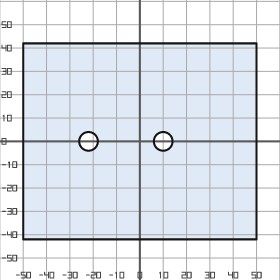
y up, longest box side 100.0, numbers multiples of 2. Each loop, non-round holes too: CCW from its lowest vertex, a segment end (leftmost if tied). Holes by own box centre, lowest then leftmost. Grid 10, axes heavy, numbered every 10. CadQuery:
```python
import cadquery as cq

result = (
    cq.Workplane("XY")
    .moveTo(-50.0, -42.0)
    .lineTo(50.0, -42.0)
    .lineTo(50.0, 42.0)
    .lineTo(-50.0, 42.0)
    .close()
    .moveTo(-22.0, 0.0)
    .circle(4.0)
    .moveTo(10.0, 0.0)
    .circle(4.0)
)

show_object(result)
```